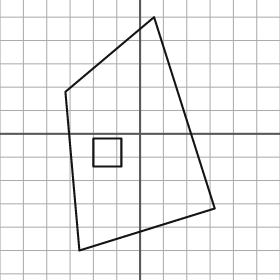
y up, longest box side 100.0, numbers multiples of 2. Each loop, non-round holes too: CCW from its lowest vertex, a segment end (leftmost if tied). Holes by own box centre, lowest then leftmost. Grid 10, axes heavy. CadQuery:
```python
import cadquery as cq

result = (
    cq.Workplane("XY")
    .moveTo(-26.0, -50.0)
    .lineTo(32.0, -32.0)
    .lineTo(6.0, 50.0)
    .lineTo(-32.0, 18.0)
    .close()
    .moveTo(-20.0, -14.0)
    .lineTo(-8.0, -14.0)
    .lineTo(-8.0, -2.0)
    .lineTo(-20.0, -2.0)
    .close()
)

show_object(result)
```